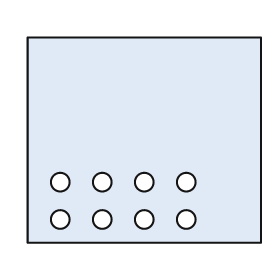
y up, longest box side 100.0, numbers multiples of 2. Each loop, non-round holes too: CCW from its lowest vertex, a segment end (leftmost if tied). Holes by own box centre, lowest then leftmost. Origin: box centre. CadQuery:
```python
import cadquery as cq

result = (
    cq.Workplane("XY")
    .moveTo(-50.0, -44.0)
    .lineTo(50.0, -44.0)
    .lineTo(50.0, 44.0)
    .lineTo(-50.0, 44.0)
    .close()
    .moveTo(-36.0, -34.0)
    .circle(4.0)
    .moveTo(-18.0, -34.0)
    .circle(4.0)
    .moveTo(0.0, -34.0)
    .circle(4.0)
    .moveTo(18.0, -34.0)
    .circle(4.0)
    .moveTo(-36.0, -18.0)
    .circle(4.0)
    .moveTo(-18.0, -18.0)
    .circle(4.0)
    .moveTo(0.0, -18.0)
    .circle(4.0)
    .moveTo(18.0, -18.0)
    .circle(4.0)
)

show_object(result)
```